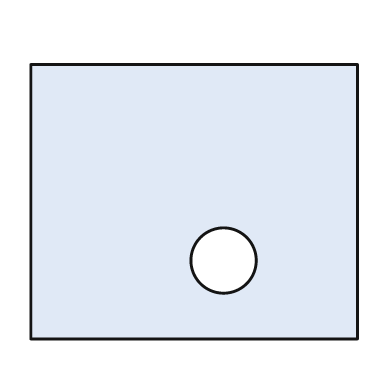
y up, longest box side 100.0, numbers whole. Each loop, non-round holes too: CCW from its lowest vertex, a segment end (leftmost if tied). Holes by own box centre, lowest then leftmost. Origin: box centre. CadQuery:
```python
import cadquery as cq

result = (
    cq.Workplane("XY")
    .moveTo(-50.0, -42.0)
    .lineTo(50.0, -42.0)
    .lineTo(50.0, 42.0)
    .lineTo(-50.0, 42.0)
    .close()
    .moveTo(9.0, -18.0)
    .circle(10.0)
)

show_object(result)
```